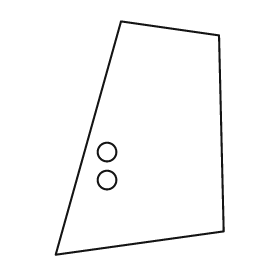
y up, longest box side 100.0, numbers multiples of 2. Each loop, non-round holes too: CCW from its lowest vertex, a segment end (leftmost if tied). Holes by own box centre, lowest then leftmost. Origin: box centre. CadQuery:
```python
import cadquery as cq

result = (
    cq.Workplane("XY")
    .moveTo(-36.0, -50.0)
    .lineTo(36.0, -40.0)
    .lineTo(34.0, 44.0)
    .lineTo(-8.0, 50.0)
    .close()
    .moveTo(-14.0, -18.0)
    .circle(4.0)
    .moveTo(-14.0, -6.0)
    .circle(4.0)
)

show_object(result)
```